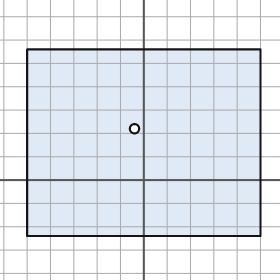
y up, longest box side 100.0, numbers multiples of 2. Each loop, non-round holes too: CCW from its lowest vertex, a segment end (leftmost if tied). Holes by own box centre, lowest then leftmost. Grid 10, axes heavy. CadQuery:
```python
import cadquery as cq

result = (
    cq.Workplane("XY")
    .moveTo(-50.0, -24.0)
    .lineTo(50.0, -24.0)
    .lineTo(50.0, 56.0)
    .lineTo(-50.0, 56.0)
    .close()
    .moveTo(-4.0, 22.0)
    .circle(2.0)
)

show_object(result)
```